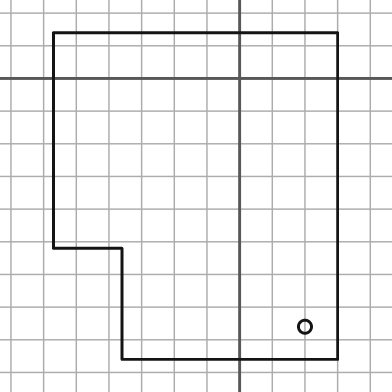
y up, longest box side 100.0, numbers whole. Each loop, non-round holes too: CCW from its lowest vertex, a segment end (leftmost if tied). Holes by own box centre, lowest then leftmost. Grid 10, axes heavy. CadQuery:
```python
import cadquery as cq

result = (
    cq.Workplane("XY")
    .moveTo(-36.0, -86.0)
    .lineTo(30.0, -86.0)
    .lineTo(30.0, 14.0)
    .lineTo(-57.0, 14.0)
    .lineTo(-57.0, -52.0)
    .lineTo(-36.0, -52.0)
    .close()
    .moveTo(20.0, -76.0)
    .circle(2.0)
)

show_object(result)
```